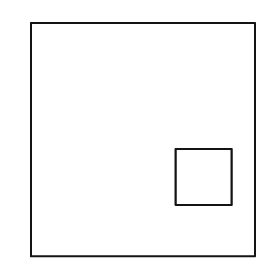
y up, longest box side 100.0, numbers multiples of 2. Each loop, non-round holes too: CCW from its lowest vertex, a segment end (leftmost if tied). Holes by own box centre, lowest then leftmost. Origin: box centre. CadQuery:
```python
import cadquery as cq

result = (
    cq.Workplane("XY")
    .moveTo(-48.0, -50.0)
    .lineTo(48.0, -50.0)
    .lineTo(48.0, 50.0)
    .lineTo(-48.0, 50.0)
    .close()
    .moveTo(14.0, -28.0)
    .lineTo(38.0, -28.0)
    .lineTo(38.0, -4.0)
    .lineTo(14.0, -4.0)
    .close()
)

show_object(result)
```